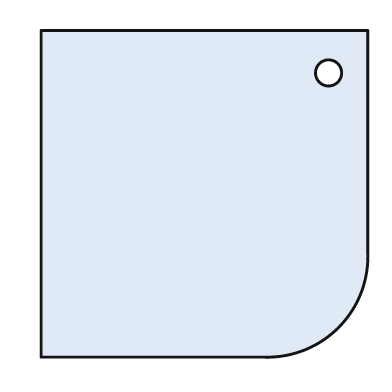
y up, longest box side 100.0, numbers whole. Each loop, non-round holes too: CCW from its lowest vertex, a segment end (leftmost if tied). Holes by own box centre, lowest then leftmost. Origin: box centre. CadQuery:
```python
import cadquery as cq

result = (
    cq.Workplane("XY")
    .moveTo(-50.0, -50.0)
    .lineTo(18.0, -50.0)
    .threePointArc((41.0, -41.0), (50.0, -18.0))
    .lineTo(50.0, 50.0)
    .lineTo(-50.0, 50.0)
    .close()
    .moveTo(38.0, 37.0)
    .circle(4.0)
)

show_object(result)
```